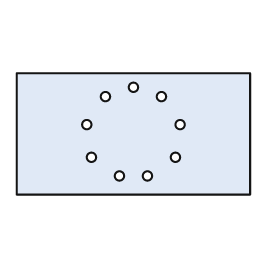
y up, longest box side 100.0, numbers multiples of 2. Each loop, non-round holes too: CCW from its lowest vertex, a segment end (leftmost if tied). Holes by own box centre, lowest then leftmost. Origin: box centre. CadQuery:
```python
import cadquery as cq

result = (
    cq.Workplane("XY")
    .moveTo(-50.0, -26.0)
    .lineTo(50.0, -26.0)
    .lineTo(50.0, 26.0)
    .lineTo(-50.0, 26.0)
    .close()
    .moveTo(-6.0, -18.0)
    .circle(2.0)
    .moveTo(6.0, -18.0)
    .circle(2.0)
    .moveTo(-18.0, -10.0)
    .circle(2.0)
    .moveTo(18.0, -10.0)
    .circle(2.0)
    .moveTo(-20.0, 4.0)
    .circle(2.0)
    .moveTo(20.0, 4.0)
    .circle(2.0)
    .moveTo(-12.0, 16.0)
    .circle(2.0)
    .moveTo(12.0, 16.0)
    .circle(2.0)
    .moveTo(0.0, 20.0)
    .circle(2.0)
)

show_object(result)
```